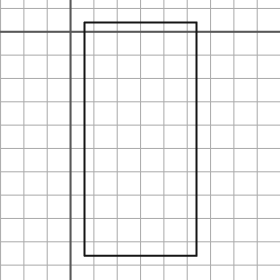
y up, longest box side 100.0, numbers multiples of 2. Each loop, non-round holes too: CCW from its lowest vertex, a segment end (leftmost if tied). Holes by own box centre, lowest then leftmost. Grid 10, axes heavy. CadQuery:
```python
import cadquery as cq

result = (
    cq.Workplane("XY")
    .moveTo(6.0, -96.0)
    .lineTo(54.0, -96.0)
    .lineTo(54.0, 4.0)
    .lineTo(6.0, 4.0)
    .close()
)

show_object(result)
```